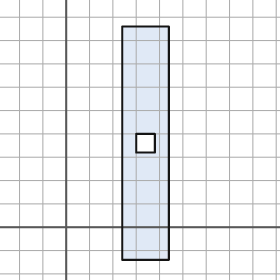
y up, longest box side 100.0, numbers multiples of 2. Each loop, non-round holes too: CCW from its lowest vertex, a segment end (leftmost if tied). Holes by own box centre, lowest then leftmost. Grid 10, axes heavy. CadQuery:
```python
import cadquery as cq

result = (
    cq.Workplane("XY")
    .moveTo(24.0, -14.0)
    .lineTo(44.0, -14.0)
    .lineTo(44.0, 86.0)
    .lineTo(24.0, 86.0)
    .close()
    .moveTo(30.0, 32.0)
    .lineTo(38.0, 32.0)
    .lineTo(38.0, 40.0)
    .lineTo(30.0, 40.0)
    .close()
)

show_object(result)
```